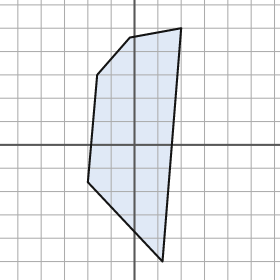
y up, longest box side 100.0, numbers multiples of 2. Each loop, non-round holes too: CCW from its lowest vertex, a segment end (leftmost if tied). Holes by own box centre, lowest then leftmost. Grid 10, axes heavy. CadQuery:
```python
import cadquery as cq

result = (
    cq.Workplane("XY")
    .moveTo(12.0, -50.0)
    .lineTo(20.0, 50.0)
    .lineTo(-2.0, 46.0)
    .lineTo(-16.0, 30.0)
    .lineTo(-20.0, -16.0)
    .close()
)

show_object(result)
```